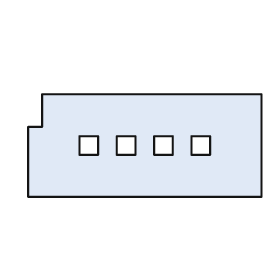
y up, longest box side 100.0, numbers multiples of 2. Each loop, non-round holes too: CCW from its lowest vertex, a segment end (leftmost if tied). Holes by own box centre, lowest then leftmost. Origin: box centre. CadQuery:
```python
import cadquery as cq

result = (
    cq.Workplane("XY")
    .moveTo(-50.0, -22.0)
    .lineTo(50.0, -22.0)
    .lineTo(50.0, 22.0)
    .lineTo(-44.0, 22.0)
    .lineTo(-44.0, 8.0)
    .lineTo(-50.0, 8.0)
    .close()
    .moveTo(-28.0, -4.0)
    .lineTo(-20.0, -4.0)
    .lineTo(-20.0, 4.0)
    .lineTo(-28.0, 4.0)
    .close()
    .moveTo(-12.0, -4.0)
    .lineTo(-4.0, -4.0)
    .lineTo(-4.0, 4.0)
    .lineTo(-12.0, 4.0)
    .close()
    .moveTo(4.0, -4.0)
    .lineTo(12.0, -4.0)
    .lineTo(12.0, 4.0)
    .lineTo(4.0, 4.0)
    .close()
    .moveTo(20.0, -4.0)
    .lineTo(28.0, -4.0)
    .lineTo(28.0, 4.0)
    .lineTo(20.0, 4.0)
    .close()
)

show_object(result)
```